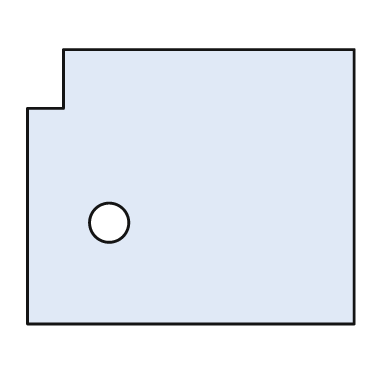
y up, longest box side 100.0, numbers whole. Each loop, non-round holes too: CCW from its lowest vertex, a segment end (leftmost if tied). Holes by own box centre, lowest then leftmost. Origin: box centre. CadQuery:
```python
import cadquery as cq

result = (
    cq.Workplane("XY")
    .moveTo(-50.0, -42.0)
    .lineTo(50.0, -42.0)
    .lineTo(50.0, 42.0)
    .lineTo(-39.0, 42.0)
    .lineTo(-39.0, 24.0)
    .lineTo(-50.0, 24.0)
    .close()
    .moveTo(-25.0, -11.0)
    .circle(6.0)
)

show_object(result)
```